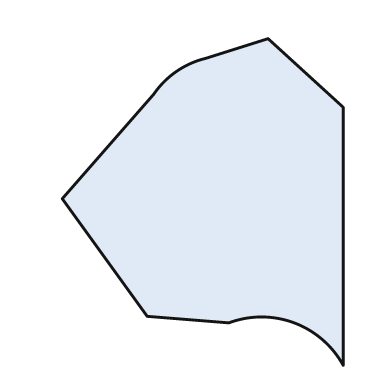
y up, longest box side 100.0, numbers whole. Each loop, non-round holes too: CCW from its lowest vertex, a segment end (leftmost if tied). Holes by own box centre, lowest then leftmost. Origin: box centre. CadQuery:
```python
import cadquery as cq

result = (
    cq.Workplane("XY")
    .moveTo(43.0, -50.0)
    .lineTo(43.0, 29.0)
    .lineTo(20.0, 50.0)
    .lineTo(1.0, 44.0)
    .threePointArc((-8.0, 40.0), (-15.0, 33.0))
    .lineTo(-43.0, 1.0)
    .lineTo(-17.0, -35.0)
    .lineTo(8.0, -37.0)
    .threePointArc((28.0, -37.0), (43.0, -50.0))
    .close()
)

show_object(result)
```